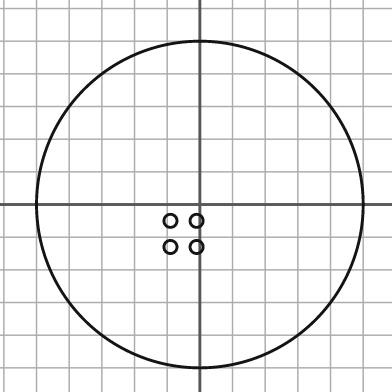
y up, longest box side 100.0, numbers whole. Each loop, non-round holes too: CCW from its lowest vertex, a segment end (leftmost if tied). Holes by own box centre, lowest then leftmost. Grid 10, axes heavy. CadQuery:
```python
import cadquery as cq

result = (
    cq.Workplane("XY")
    .moveTo(0.0, 0.0)
    .circle(50.0)
    .moveTo(-9.0, -13.0)
    .circle(2.0)
    .moveTo(-1.0, -13.0)
    .circle(2.0)
    .moveTo(-9.0, -5.0)
    .circle(2.0)
    .moveTo(-1.0, -5.0)
    .circle(2.0)
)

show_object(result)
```